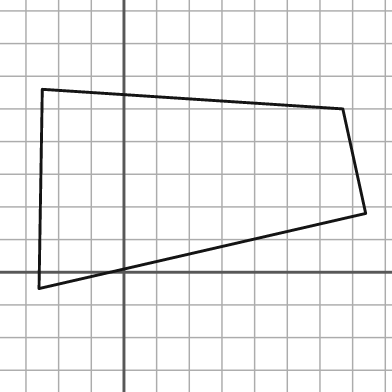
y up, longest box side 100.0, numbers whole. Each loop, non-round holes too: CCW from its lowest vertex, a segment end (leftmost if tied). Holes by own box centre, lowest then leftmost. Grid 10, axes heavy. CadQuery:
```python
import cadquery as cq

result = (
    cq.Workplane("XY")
    .moveTo(-26.0, -5.0)
    .lineTo(74.0, 18.0)
    .lineTo(67.0, 50.0)
    .lineTo(-25.0, 56.0)
    .close()
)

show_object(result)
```